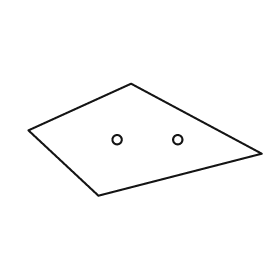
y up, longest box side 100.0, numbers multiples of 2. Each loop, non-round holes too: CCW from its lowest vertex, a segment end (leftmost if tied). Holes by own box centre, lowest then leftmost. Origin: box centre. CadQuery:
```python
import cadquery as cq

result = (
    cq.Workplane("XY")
    .moveTo(-20.0, -24.0)
    .lineTo(50.0, -6.0)
    .lineTo(-6.0, 24.0)
    .lineTo(-50.0, 4.0)
    .close()
    .moveTo(-12.0, 0.0)
    .circle(2.0)
    .moveTo(14.0, 0.0)
    .circle(2.0)
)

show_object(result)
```